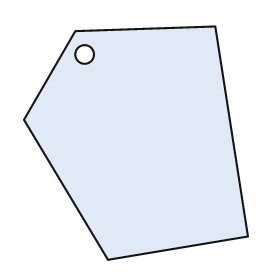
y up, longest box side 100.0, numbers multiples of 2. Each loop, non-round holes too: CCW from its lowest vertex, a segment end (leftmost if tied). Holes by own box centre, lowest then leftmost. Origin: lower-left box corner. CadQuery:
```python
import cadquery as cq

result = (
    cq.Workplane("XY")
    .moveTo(36.0, 0.0)
    .lineTo(96.0, 10.0)
    .lineTo(82.0, 100.0)
    .lineTo(22.0, 98.0)
    .lineTo(0.0, 60.0)
    .close()
    .moveTo(26.0, 88.0)
    .circle(4.0)
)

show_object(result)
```